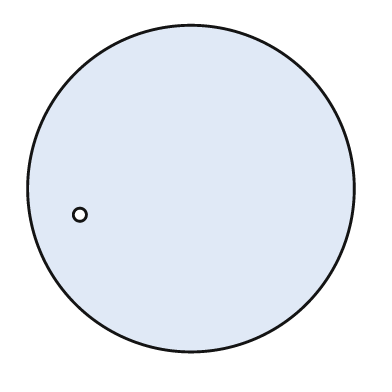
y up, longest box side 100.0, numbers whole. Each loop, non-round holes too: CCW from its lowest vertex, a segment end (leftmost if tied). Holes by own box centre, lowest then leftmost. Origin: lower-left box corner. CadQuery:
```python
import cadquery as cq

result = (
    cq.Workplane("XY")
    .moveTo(50.0, 50.0)
    .circle(50.0)
    .moveTo(16.0, 42.0)
    .circle(2.0)
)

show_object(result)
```